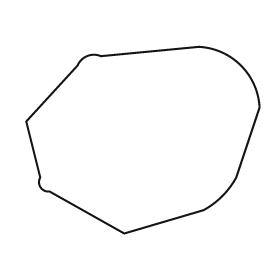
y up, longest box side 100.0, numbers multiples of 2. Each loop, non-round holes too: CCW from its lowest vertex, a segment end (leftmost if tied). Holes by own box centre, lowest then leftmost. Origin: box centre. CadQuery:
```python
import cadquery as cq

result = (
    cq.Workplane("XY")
    .moveTo(-8.0, -40.0)
    .lineTo(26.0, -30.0)
    .threePointArc((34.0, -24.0), (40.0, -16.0))
    .lineTo(50.0, 14.0)
    .threePointArc((42.0, 32.0), (24.0, 40.0))
    .lineTo(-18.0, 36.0)
    .threePointArc((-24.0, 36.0), (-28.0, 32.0))
    .lineTo(-50.0, 8.0)
    .lineTo(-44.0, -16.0)
    .threePointArc((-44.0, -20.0), (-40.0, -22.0))
    .close()
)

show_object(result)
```